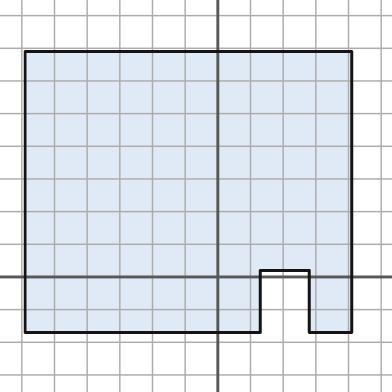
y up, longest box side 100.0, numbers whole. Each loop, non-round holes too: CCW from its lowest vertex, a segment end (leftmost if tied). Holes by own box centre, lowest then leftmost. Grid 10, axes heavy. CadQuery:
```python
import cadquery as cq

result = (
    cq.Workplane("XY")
    .moveTo(-59.0, -17.0)
    .lineTo(13.0, -17.0)
    .lineTo(13.0, 2.0)
    .lineTo(28.0, 2.0)
    .lineTo(28.0, -17.0)
    .lineTo(41.0, -17.0)
    .lineTo(41.0, 69.0)
    .lineTo(-59.0, 69.0)
    .close()
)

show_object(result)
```